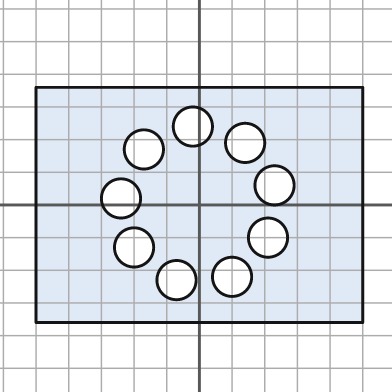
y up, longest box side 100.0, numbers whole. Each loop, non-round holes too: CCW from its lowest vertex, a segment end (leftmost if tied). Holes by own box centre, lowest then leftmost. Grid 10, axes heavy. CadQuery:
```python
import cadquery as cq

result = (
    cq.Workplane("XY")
    .moveTo(-50.0, -36.0)
    .lineTo(50.0, -36.0)
    .lineTo(50.0, 36.0)
    .lineTo(-50.0, 36.0)
    .close()
    .moveTo(-7.0, -23.0)
    .circle(6.0)
    .moveTo(10.0, -22.0)
    .circle(6.0)
    .moveTo(-20.0, -13.0)
    .circle(6.0)
    .moveTo(21.0, -10.0)
    .circle(6.0)
    .moveTo(-24.0, 2.0)
    .circle(6.0)
    .moveTo(23.0, 6.0)
    .circle(6.0)
    .moveTo(-17.0, 17.0)
    .circle(6.0)
    .moveTo(14.0, 19.0)
    .circle(6.0)
    .moveTo(-2.0, 24.0)
    .circle(6.0)
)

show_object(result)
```